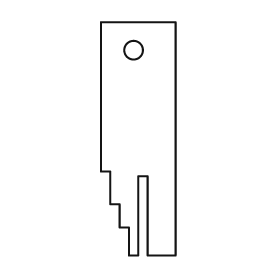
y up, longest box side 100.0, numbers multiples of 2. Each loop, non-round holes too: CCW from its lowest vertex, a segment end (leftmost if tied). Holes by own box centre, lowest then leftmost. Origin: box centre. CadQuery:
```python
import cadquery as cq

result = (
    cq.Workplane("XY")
    .moveTo(-4.0, -50.0)
    .lineTo(0.0, -50.0)
    .lineTo(0.0, -16.0)
    .lineTo(4.0, -16.0)
    .lineTo(4.0, -50.0)
    .lineTo(16.0, -50.0)
    .lineTo(16.0, 50.0)
    .lineTo(-16.0, 50.0)
    .lineTo(-16.0, -14.0)
    .lineTo(-12.0, -14.0)
    .lineTo(-12.0, -28.0)
    .lineTo(-8.0, -28.0)
    .lineTo(-8.0, -38.0)
    .lineTo(-4.0, -38.0)
    .close()
    .moveTo(-2.0, 38.0)
    .circle(4.0)
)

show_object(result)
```